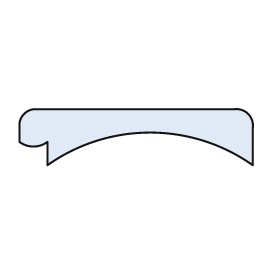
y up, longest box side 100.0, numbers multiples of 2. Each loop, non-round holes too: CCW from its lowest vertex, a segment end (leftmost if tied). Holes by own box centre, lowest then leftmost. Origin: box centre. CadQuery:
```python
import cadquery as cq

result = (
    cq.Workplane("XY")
    .moveTo(-38.0, -12.0)
    .threePointArc((6.0, 2.0), (50.0, -12.0))
    .lineTo(50.0, 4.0)
    .threePointArc((48.0, 10.0), (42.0, 12.0))
    .lineTo(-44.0, 12.0)
    .threePointArc((-48.0, 10.0), (-50.0, 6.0))
    .lineTo(-50.0, -2.0)
    .threePointArc((-44.0, -4.0), (-38.0, -2.0))
    .close()
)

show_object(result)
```